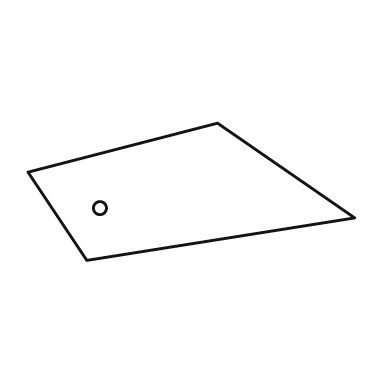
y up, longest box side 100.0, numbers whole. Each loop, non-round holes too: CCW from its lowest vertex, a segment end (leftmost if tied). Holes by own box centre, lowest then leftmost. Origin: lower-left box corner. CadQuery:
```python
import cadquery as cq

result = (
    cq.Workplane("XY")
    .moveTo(18.0, 0.0)
    .lineTo(100.0, 13.0)
    .lineTo(58.0, 42.0)
    .lineTo(0.0, 27.0)
    .close()
    .moveTo(22.0, 16.0)
    .circle(2.0)
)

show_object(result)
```